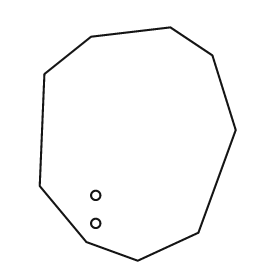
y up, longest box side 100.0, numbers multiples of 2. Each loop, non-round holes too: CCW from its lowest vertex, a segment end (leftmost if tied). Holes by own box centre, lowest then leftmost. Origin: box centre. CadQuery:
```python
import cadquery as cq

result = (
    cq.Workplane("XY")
    .moveTo(0.0, -50.0)
    .lineTo(26.0, -38.0)
    .lineTo(42.0, 6.0)
    .lineTo(32.0, 38.0)
    .lineTo(14.0, 50.0)
    .lineTo(-20.0, 46.0)
    .lineTo(-40.0, 30.0)
    .lineTo(-42.0, -18.0)
    .lineTo(-22.0, -42.0)
    .close()
    .moveTo(-18.0, -34.0)
    .circle(2.0)
    .moveTo(-18.0, -22.0)
    .circle(2.0)
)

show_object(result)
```